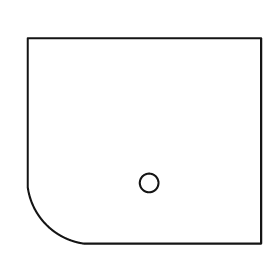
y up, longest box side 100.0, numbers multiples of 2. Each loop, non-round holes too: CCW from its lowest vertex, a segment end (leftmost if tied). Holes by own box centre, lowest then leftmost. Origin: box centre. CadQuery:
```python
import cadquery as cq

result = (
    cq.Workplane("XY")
    .moveTo(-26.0, -44.0)
    .lineTo(50.0, -44.0)
    .lineTo(50.0, 44.0)
    .lineTo(-50.0, 44.0)
    .lineTo(-50.0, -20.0)
    .threePointArc((-42.0, -36.0), (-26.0, -44.0))
    .close()
    .moveTo(2.0, -18.0)
    .circle(4.0)
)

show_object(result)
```